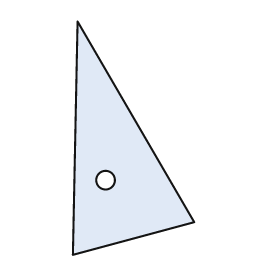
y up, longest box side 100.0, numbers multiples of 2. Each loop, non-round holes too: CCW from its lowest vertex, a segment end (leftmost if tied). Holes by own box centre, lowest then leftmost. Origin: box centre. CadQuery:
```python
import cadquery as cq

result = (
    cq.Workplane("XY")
    .moveTo(-26.0, -50.0)
    .lineTo(26.0, -36.0)
    .lineTo(-24.0, 50.0)
    .close()
    .moveTo(-12.0, -18.0)
    .circle(4.0)
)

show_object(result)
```